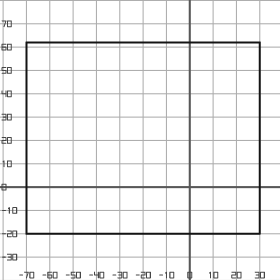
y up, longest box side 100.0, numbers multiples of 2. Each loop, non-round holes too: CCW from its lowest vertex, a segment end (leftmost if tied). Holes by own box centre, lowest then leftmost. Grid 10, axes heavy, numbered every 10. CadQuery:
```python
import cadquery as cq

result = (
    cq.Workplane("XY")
    .moveTo(-70.0, -20.0)
    .lineTo(30.0, -20.0)
    .lineTo(30.0, 62.0)
    .lineTo(-70.0, 62.0)
    .close()
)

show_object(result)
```